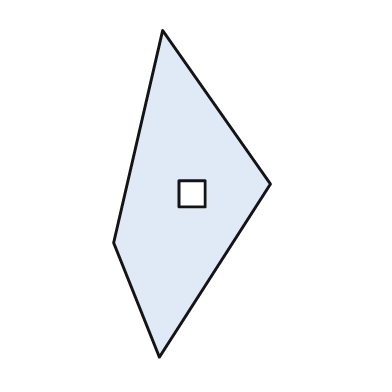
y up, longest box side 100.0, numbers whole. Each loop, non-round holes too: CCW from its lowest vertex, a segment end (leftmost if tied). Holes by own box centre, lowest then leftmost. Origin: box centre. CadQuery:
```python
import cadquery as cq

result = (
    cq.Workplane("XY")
    .moveTo(-10.0, -50.0)
    .lineTo(24.0, 3.0)
    .lineTo(-9.0, 50.0)
    .lineTo(-24.0, -15.0)
    .close()
    .moveTo(-4.0, -4.0)
    .lineTo(4.0, -4.0)
    .lineTo(4.0, 4.0)
    .lineTo(-4.0, 4.0)
    .close()
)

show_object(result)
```